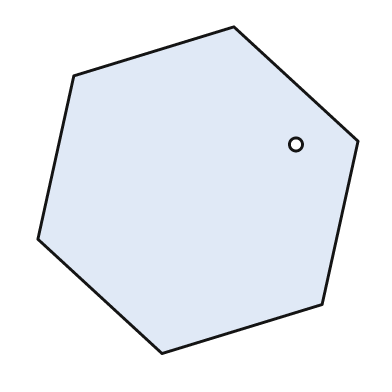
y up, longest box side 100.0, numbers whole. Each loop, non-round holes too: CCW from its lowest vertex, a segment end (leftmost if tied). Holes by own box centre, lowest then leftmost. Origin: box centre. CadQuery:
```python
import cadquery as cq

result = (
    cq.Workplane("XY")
    .moveTo(-11.0, -50.0)
    .lineTo(38.0, -35.0)
    .lineTo(49.0, 15.0)
    .lineTo(11.0, 50.0)
    .lineTo(-38.0, 35.0)
    .lineTo(-49.0, -15.0)
    .close()
    .moveTo(30.0, 14.0)
    .circle(2.0)
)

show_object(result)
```